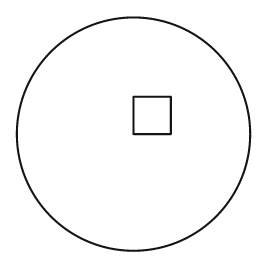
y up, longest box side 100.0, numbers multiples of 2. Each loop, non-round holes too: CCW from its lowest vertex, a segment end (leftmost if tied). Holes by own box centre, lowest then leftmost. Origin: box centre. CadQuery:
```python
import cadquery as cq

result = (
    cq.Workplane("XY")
    .moveTo(0.0, 0.0)
    .circle(50.0)
    .moveTo(0.0, 0.0)
    .lineTo(16.0, 0.0)
    .lineTo(16.0, 16.0)
    .lineTo(0.0, 16.0)
    .close()
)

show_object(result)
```